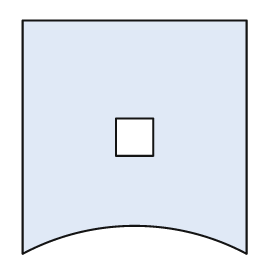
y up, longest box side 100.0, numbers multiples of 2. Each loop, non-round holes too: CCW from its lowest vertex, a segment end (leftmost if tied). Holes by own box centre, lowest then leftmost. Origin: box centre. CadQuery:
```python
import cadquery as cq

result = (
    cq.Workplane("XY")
    .moveTo(-48.0, -50.0)
    .threePointArc((0.0, -38.0), (48.0, -50.0))
    .lineTo(48.0, 50.0)
    .lineTo(-48.0, 50.0)
    .close()
    .moveTo(-8.0, -8.0)
    .lineTo(8.0, -8.0)
    .lineTo(8.0, 8.0)
    .lineTo(-8.0, 8.0)
    .close()
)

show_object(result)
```